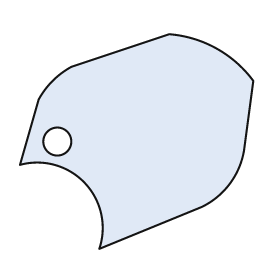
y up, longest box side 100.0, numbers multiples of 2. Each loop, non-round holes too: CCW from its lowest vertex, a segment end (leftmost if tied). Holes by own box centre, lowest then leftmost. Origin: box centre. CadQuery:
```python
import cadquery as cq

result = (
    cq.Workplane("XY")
    .moveTo(-16.0, -46.0)
    .lineTo(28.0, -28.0)
    .threePointArc((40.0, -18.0), (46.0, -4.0))
    .lineTo(50.0, 26.0)
    .threePointArc((34.0, 40.0), (14.0, 46.0))
    .lineTo(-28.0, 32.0)
    .threePointArc((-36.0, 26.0), (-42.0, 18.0))
    .lineTo(-50.0, -10.0)
    .threePointArc((-22.0, -18.0), (-16.0, -46.0))
    .close()
    .moveTo(-34.0, 0.0)
    .circle(6.0)
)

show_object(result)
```